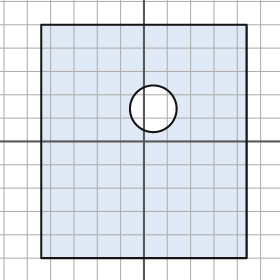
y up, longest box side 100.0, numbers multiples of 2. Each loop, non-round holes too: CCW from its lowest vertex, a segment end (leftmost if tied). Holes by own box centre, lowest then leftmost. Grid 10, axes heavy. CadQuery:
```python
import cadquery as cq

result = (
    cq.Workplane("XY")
    .moveTo(-44.0, -50.0)
    .lineTo(44.0, -50.0)
    .lineTo(44.0, 50.0)
    .lineTo(-44.0, 50.0)
    .close()
    .moveTo(4.0, 14.0)
    .circle(10.0)
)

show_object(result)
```